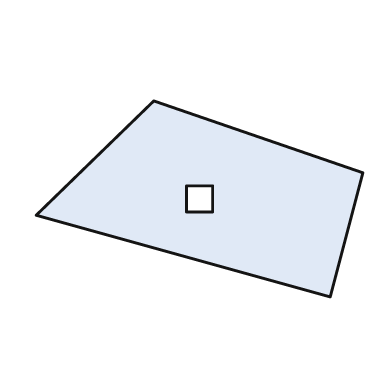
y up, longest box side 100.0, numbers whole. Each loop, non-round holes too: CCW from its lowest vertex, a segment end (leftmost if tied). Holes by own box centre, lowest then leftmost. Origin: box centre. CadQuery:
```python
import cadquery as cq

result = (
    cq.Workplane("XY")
    .moveTo(40.0, -30.0)
    .lineTo(50.0, 8.0)
    .lineTo(-14.0, 30.0)
    .lineTo(-50.0, -5.0)
    .close()
    .moveTo(-4.0, -4.0)
    .lineTo(4.0, -4.0)
    .lineTo(4.0, 4.0)
    .lineTo(-4.0, 4.0)
    .close()
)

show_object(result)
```